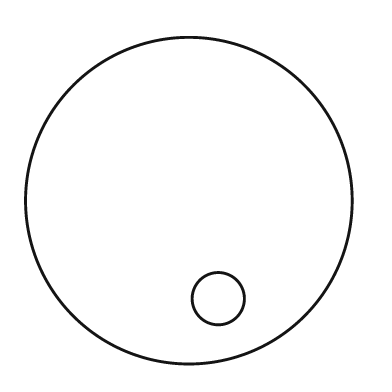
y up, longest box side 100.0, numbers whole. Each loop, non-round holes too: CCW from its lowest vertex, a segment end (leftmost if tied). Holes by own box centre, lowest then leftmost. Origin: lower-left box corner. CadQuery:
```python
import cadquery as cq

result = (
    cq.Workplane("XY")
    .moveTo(50.0, 50.0)
    .circle(50.0)
    .moveTo(59.0, 20.0)
    .circle(8.0)
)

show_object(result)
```